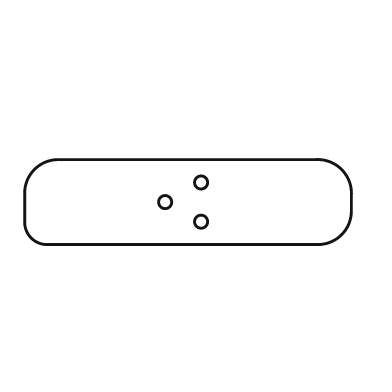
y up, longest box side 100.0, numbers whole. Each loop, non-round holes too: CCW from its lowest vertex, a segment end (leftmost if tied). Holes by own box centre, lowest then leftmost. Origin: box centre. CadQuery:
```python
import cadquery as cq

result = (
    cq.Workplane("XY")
    .moveTo(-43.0, -13.0)
    .lineTo(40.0, -13.0)
    .threePointArc((47.0, -10.0), (50.0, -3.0))
    .lineTo(50.0, 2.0)
    .threePointArc((47.0, 10.0), (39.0, 13.0))
    .lineTo(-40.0, 13.0)
    .threePointArc((-47.0, 10.0), (-50.0, 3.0))
    .lineTo(-50.0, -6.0)
    .threePointArc((-48.0, -11.0), (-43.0, -13.0))
    .close()
    .moveTo(4.0, -6.0)
    .circle(2.0)
    .moveTo(-7.0, 0.0)
    .circle(2.0)
    .moveTo(4.0, 6.0)
    .circle(2.0)
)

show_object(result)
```